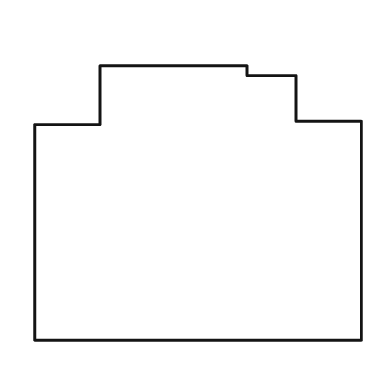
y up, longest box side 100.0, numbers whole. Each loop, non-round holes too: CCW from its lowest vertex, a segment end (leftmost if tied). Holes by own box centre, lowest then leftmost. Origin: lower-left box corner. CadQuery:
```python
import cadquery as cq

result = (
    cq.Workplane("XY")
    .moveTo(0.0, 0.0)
    .lineTo(100.0, 0.0)
    .lineTo(100.0, 67.0)
    .lineTo(80.0, 67.0)
    .lineTo(80.0, 81.0)
    .lineTo(65.0, 81.0)
    .lineTo(65.0, 84.0)
    .lineTo(20.0, 84.0)
    .lineTo(20.0, 66.0)
    .lineTo(0.0, 66.0)
    .close()
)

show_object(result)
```